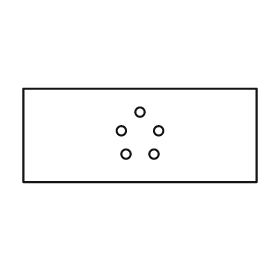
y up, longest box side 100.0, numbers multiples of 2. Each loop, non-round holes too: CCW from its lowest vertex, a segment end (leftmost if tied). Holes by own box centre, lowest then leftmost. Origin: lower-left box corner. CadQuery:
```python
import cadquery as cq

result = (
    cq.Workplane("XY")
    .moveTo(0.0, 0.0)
    .lineTo(100.0, 0.0)
    .lineTo(100.0, 40.0)
    .lineTo(0.0, 40.0)
    .close()
    .moveTo(44.0, 12.0)
    .circle(2.0)
    .moveTo(56.0, 12.0)
    .circle(2.0)
    .moveTo(42.0, 22.0)
    .circle(2.0)
    .moveTo(58.0, 22.0)
    .circle(2.0)
    .moveTo(50.0, 30.0)
    .circle(2.0)
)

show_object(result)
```